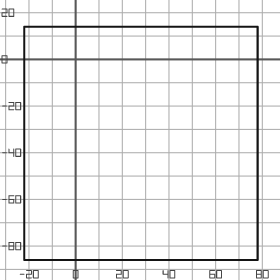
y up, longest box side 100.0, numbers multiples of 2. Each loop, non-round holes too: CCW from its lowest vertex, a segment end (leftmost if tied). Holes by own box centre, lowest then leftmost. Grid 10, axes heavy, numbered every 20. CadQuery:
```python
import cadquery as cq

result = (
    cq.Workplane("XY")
    .moveTo(-22.0, -86.0)
    .lineTo(78.0, -86.0)
    .lineTo(78.0, 14.0)
    .lineTo(-22.0, 14.0)
    .close()
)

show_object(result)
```